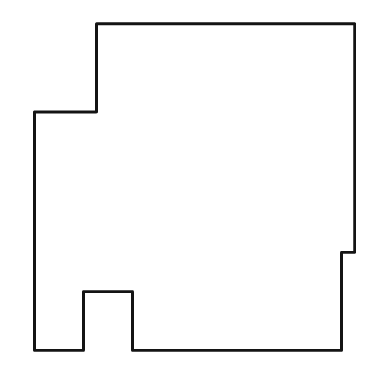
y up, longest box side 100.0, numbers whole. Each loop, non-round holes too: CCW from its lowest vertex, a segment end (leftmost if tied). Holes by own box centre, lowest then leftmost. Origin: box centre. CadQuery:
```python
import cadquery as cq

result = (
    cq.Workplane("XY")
    .moveTo(-49.0, -50.0)
    .lineTo(-34.0, -50.0)
    .lineTo(-34.0, -32.0)
    .lineTo(-19.0, -32.0)
    .lineTo(-19.0, -50.0)
    .lineTo(45.0, -50.0)
    .lineTo(45.0, -20.0)
    .lineTo(49.0, -20.0)
    .lineTo(49.0, 50.0)
    .lineTo(-30.0, 50.0)
    .lineTo(-30.0, 23.0)
    .lineTo(-49.0, 23.0)
    .close()
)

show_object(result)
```